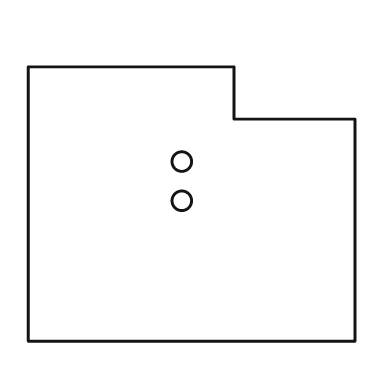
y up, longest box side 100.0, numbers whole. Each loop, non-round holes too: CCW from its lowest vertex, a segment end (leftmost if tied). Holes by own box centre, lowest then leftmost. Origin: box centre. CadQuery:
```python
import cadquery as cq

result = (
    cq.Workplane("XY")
    .moveTo(-50.0, -42.0)
    .lineTo(50.0, -42.0)
    .lineTo(50.0, 26.0)
    .lineTo(13.0, 26.0)
    .lineTo(13.0, 42.0)
    .lineTo(-50.0, 42.0)
    .close()
    .moveTo(-3.0, 1.0)
    .circle(3.0)
    .moveTo(-3.0, 13.0)
    .circle(3.0)
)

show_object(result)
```